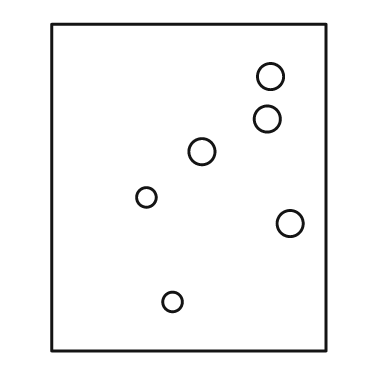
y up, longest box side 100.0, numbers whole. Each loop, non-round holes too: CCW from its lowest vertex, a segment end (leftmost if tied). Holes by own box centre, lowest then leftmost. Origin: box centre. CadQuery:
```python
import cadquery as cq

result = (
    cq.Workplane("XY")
    .moveTo(-42.0, -50.0)
    .lineTo(42.0, -50.0)
    .lineTo(42.0, 50.0)
    .lineTo(-42.0, 50.0)
    .close()
    .moveTo(-5.0, -35.0)
    .circle(3.0)
    .moveTo(31.0, -11.0)
    .circle(4.0)
    .moveTo(-13.0, -3.0)
    .circle(3.0)
    .moveTo(4.0, 11.0)
    .circle(4.0)
    .moveTo(24.0, 21.0)
    .circle(4.0)
    .moveTo(25.0, 34.0)
    .circle(4.0)
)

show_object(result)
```